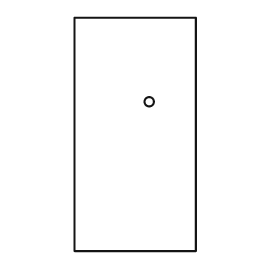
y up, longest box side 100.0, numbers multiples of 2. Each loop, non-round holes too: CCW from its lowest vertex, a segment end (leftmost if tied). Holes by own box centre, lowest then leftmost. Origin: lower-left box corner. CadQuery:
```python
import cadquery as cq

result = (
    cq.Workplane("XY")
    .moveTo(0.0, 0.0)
    .lineTo(52.0, 0.0)
    .lineTo(52.0, 100.0)
    .lineTo(0.0, 100.0)
    .close()
    .moveTo(32.0, 64.0)
    .circle(2.0)
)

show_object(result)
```